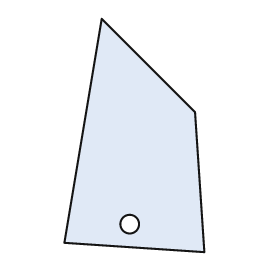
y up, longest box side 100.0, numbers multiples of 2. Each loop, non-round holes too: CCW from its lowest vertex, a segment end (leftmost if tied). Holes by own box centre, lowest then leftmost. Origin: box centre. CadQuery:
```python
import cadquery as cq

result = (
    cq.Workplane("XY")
    .moveTo(30.0, -50.0)
    .lineTo(26.0, 10.0)
    .lineTo(-14.0, 50.0)
    .lineTo(-30.0, -46.0)
    .close()
    .moveTo(-2.0, -38.0)
    .circle(4.0)
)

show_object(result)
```